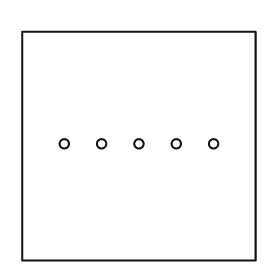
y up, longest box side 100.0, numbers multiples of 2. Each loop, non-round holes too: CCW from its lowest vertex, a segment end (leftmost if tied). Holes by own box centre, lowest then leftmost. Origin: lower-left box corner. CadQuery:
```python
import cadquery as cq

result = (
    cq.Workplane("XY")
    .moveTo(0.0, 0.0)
    .lineTo(100.0, 0.0)
    .lineTo(100.0, 98.0)
    .lineTo(0.0, 98.0)
    .close()
    .moveTo(18.0, 50.0)
    .circle(2.0)
    .moveTo(34.0, 50.0)
    .circle(2.0)
    .moveTo(50.0, 50.0)
    .circle(2.0)
    .moveTo(66.0, 50.0)
    .circle(2.0)
    .moveTo(82.0, 50.0)
    .circle(2.0)
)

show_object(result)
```